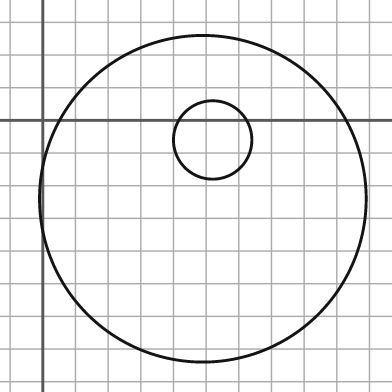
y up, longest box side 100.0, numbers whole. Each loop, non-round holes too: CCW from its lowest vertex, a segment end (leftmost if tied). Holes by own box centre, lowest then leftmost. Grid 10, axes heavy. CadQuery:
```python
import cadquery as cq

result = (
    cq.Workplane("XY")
    .moveTo(49.0, -24.0)
    .circle(50.0)
    .moveTo(52.0, -6.0)
    .circle(12.0)
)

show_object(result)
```